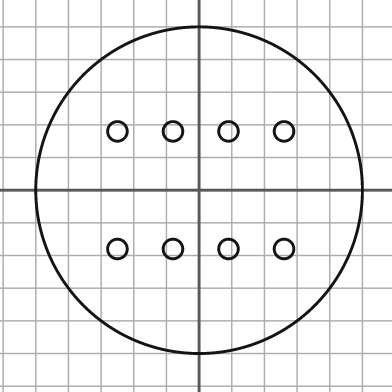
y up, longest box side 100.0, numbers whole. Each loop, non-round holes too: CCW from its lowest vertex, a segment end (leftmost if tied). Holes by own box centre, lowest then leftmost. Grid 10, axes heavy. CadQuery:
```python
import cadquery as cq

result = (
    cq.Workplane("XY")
    .moveTo(0.0, 0.0)
    .circle(50.0)
    .moveTo(-25.0, -18.0)
    .circle(3.0)
    .moveTo(-8.0, -18.0)
    .circle(3.0)
    .moveTo(9.0, -18.0)
    .circle(3.0)
    .moveTo(26.0, -18.0)
    .circle(3.0)
    .moveTo(-25.0, 18.0)
    .circle(3.0)
    .moveTo(-8.0, 18.0)
    .circle(3.0)
    .moveTo(9.0, 18.0)
    .circle(3.0)
    .moveTo(26.0, 18.0)
    .circle(3.0)
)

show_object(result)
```